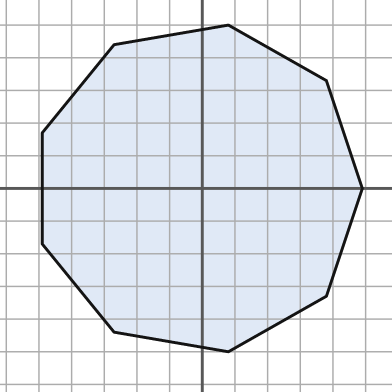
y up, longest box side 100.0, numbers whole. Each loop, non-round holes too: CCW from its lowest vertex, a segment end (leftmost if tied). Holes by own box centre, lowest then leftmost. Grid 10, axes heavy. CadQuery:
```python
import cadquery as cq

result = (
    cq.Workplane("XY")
    .moveTo(8.0, -50.0)
    .lineTo(38.0, -33.0)
    .lineTo(49.0, 0.0)
    .lineTo(38.0, 33.0)
    .lineTo(8.0, 50.0)
    .lineTo(-27.0, 44.0)
    .lineTo(-49.0, 17.0)
    .lineTo(-49.0, -17.0)
    .lineTo(-27.0, -44.0)
    .close()
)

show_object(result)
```